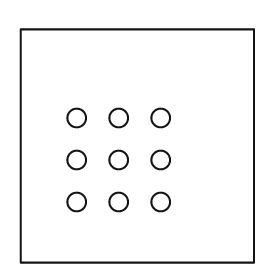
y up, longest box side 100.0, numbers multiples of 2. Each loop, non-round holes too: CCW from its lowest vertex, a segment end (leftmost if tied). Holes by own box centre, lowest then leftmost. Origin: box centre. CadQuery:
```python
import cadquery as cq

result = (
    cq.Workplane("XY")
    .moveTo(-50.0, -50.0)
    .lineTo(50.0, -50.0)
    .lineTo(50.0, 50.0)
    .lineTo(-50.0, 50.0)
    .close()
    .moveTo(-26.0, -24.0)
    .circle(4.0)
    .moveTo(-8.0, -24.0)
    .circle(4.0)
    .moveTo(10.0, -24.0)
    .circle(4.0)
    .moveTo(-26.0, -6.0)
    .circle(4.0)
    .moveTo(-8.0, -6.0)
    .circle(4.0)
    .moveTo(10.0, -6.0)
    .circle(4.0)
    .moveTo(-26.0, 12.0)
    .circle(4.0)
    .moveTo(-8.0, 12.0)
    .circle(4.0)
    .moveTo(10.0, 12.0)
    .circle(4.0)
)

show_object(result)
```